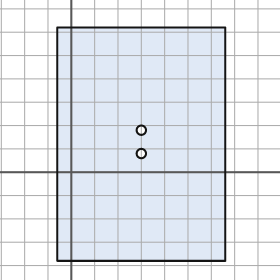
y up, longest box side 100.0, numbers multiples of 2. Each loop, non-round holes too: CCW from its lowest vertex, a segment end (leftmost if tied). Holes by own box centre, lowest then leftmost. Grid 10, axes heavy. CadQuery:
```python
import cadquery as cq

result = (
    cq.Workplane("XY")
    .moveTo(-6.0, -38.0)
    .lineTo(66.0, -38.0)
    .lineTo(66.0, 62.0)
    .lineTo(-6.0, 62.0)
    .close()
    .moveTo(30.0, 8.0)
    .circle(2.0)
    .moveTo(30.0, 18.0)
    .circle(2.0)
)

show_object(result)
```